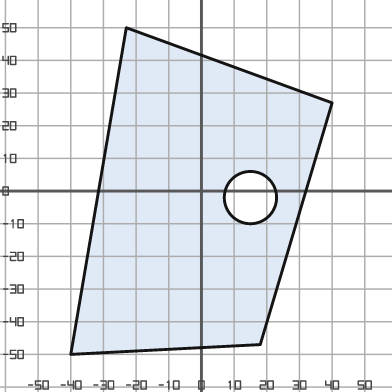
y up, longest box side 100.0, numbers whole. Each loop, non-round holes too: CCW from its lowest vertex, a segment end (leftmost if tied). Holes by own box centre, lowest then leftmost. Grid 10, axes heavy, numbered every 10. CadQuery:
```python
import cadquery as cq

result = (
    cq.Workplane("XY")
    .moveTo(-40.0, -50.0)
    .lineTo(18.0, -47.0)
    .lineTo(40.0, 27.0)
    .lineTo(-23.0, 50.0)
    .close()
    .moveTo(15.0, -2.0)
    .circle(8.0)
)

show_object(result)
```